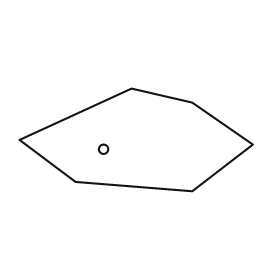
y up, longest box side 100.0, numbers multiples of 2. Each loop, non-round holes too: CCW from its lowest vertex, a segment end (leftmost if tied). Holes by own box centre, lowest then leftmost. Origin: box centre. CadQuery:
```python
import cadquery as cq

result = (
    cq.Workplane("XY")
    .moveTo(24.0, -22.0)
    .lineTo(50.0, -2.0)
    .lineTo(24.0, 16.0)
    .lineTo(-2.0, 22.0)
    .lineTo(-50.0, 0.0)
    .lineTo(-26.0, -18.0)
    .close()
    .moveTo(-14.0, -4.0)
    .circle(2.0)
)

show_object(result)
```